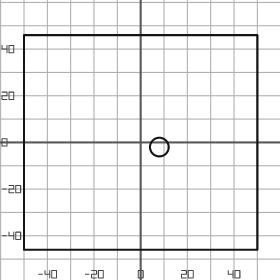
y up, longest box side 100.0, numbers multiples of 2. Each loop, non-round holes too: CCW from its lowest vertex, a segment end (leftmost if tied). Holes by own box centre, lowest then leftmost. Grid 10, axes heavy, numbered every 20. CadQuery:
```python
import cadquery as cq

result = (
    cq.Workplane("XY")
    .moveTo(-50.0, -46.0)
    .lineTo(50.0, -46.0)
    .lineTo(50.0, 46.0)
    .lineTo(-50.0, 46.0)
    .close()
    .moveTo(8.0, -2.0)
    .circle(4.0)
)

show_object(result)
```